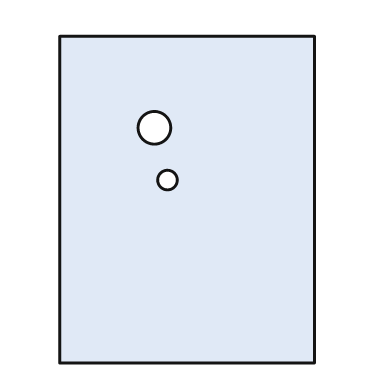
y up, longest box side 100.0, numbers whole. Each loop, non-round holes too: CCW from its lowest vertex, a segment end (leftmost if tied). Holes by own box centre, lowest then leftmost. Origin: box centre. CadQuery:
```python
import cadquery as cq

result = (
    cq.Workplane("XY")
    .moveTo(-39.0, -50.0)
    .lineTo(39.0, -50.0)
    .lineTo(39.0, 50.0)
    .lineTo(-39.0, 50.0)
    .close()
    .moveTo(-6.0, 6.0)
    .circle(3.0)
    .moveTo(-10.0, 22.0)
    .circle(5.0)
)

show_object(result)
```